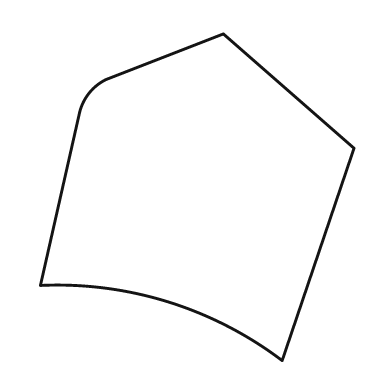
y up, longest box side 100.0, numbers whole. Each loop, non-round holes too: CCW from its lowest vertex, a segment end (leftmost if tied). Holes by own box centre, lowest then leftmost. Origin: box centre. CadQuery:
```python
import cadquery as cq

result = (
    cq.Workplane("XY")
    .moveTo(26.0, -50.0)
    .lineTo(48.0, 15.0)
    .lineTo(8.0, 50.0)
    .lineTo(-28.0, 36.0)
    .threePointArc((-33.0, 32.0), (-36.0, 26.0))
    .lineTo(-48.0, -27.0)
    .threePointArc((-9.0, -32.0), (26.0, -50.0))
    .close()
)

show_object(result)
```